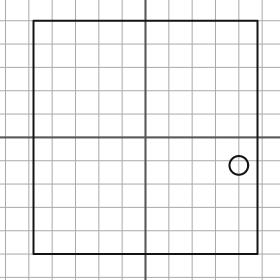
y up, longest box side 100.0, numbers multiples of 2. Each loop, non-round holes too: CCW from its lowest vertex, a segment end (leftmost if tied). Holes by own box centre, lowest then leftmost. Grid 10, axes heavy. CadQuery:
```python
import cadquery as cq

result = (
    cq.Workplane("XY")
    .moveTo(-48.0, -50.0)
    .lineTo(48.0, -50.0)
    .lineTo(48.0, 50.0)
    .lineTo(-48.0, 50.0)
    .close()
    .moveTo(40.0, -12.0)
    .circle(4.0)
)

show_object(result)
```